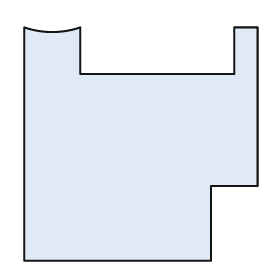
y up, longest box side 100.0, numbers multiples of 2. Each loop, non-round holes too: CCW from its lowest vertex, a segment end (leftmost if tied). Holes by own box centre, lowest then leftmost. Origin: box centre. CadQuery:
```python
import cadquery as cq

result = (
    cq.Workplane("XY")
    .moveTo(-50.0, -50.0)
    .lineTo(30.0, -50.0)
    .lineTo(30.0, -18.0)
    .lineTo(50.0, -18.0)
    .lineTo(50.0, 50.0)
    .lineTo(40.0, 50.0)
    .lineTo(40.0, 30.0)
    .lineTo(-26.0, 30.0)
    .lineTo(-26.0, 50.0)
    .threePointArc((-38.0, 48.0), (-50.0, 50.0))
    .close()
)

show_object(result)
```